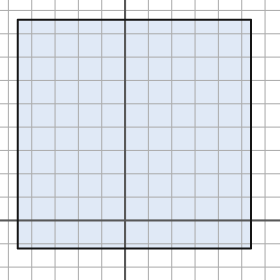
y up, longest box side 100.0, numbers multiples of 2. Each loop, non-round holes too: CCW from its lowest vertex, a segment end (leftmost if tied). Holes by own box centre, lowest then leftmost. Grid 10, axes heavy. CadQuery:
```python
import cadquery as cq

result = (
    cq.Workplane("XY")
    .moveTo(-46.0, -12.0)
    .lineTo(54.0, -12.0)
    .lineTo(54.0, 86.0)
    .lineTo(-46.0, 86.0)
    .close()
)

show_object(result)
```